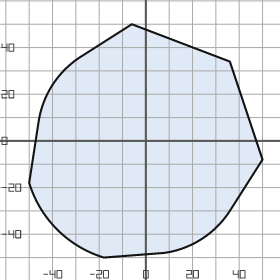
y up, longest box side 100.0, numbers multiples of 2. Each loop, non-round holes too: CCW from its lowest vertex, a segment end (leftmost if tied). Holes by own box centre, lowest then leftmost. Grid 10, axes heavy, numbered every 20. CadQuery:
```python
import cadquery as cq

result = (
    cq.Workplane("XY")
    .moveTo(-18.0, -50.0)
    .lineTo(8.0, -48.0)
    .threePointArc((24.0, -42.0), (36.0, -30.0))
    .lineTo(50.0, -8.0)
    .lineTo(36.0, 34.0)
    .lineTo(-6.0, 50.0)
    .lineTo(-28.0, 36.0)
    .threePointArc((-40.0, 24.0), (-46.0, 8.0))
    .lineTo(-50.0, -18.0)
    .threePointArc((-38.0, -38.0), (-18.0, -50.0))
    .close()
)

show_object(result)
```